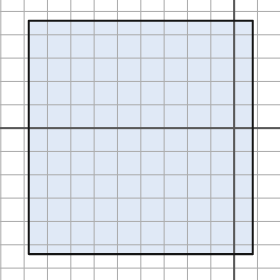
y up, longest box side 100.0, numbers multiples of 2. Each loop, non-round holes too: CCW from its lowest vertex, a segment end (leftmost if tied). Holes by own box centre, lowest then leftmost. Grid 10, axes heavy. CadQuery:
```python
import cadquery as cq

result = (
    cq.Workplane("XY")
    .moveTo(-88.0, -54.0)
    .lineTo(8.0, -54.0)
    .lineTo(8.0, 46.0)
    .lineTo(-88.0, 46.0)
    .close()
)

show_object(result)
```